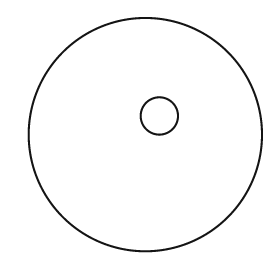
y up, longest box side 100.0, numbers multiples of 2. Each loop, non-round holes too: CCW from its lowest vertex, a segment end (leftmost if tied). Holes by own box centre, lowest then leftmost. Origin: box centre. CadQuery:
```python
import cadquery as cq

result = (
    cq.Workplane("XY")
    .moveTo(0.0, 0.0)
    .circle(50.0)
    .moveTo(6.0, 8.0)
    .circle(8.0)
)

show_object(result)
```